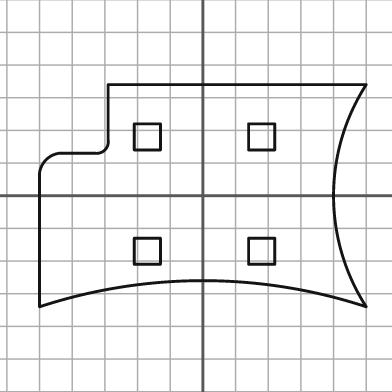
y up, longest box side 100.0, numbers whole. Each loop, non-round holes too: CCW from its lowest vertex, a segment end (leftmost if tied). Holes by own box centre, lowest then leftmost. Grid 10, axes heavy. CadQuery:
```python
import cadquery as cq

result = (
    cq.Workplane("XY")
    .moveTo(-50.0, -34.0)
    .threePointArc((0.0, -26.0), (50.0, -34.0))
    .threePointArc((40.0, 0.0), (50.0, 34.0))
    .lineTo(-29.0, 34.0)
    .lineTo(-29.0, 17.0)
    .threePointArc((-30.0, 14.0), (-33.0, 13.0))
    .lineTo(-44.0, 13.0)
    .threePointArc((-48.0, 11.0), (-50.0, 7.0))
    .close()
    .moveTo(-21.0, -21.0)
    .lineTo(-13.0, -21.0)
    .lineTo(-13.0, -13.0)
    .lineTo(-21.0, -13.0)
    .close()
    .moveTo(14.0, -21.0)
    .lineTo(22.0, -21.0)
    .lineTo(22.0, -13.0)
    .lineTo(14.0, -13.0)
    .close()
    .moveTo(-21.0, 14.0)
    .lineTo(-13.0, 14.0)
    .lineTo(-13.0, 22.0)
    .lineTo(-21.0, 22.0)
    .close()
    .moveTo(14.0, 14.0)
    .lineTo(22.0, 14.0)
    .lineTo(22.0, 22.0)
    .lineTo(14.0, 22.0)
    .close()
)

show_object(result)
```